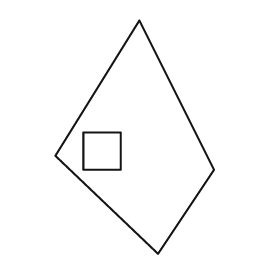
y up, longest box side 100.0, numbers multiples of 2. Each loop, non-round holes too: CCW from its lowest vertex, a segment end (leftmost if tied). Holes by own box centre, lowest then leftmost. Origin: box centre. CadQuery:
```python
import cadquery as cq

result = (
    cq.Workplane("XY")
    .moveTo(10.0, -50.0)
    .lineTo(34.0, -14.0)
    .lineTo(2.0, 50.0)
    .lineTo(-34.0, -8.0)
    .close()
    .moveTo(-22.0, -14.0)
    .lineTo(-6.0, -14.0)
    .lineTo(-6.0, 2.0)
    .lineTo(-22.0, 2.0)
    .close()
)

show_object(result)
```